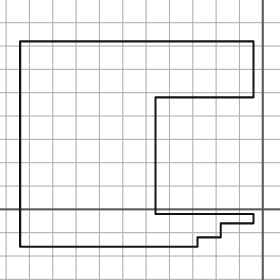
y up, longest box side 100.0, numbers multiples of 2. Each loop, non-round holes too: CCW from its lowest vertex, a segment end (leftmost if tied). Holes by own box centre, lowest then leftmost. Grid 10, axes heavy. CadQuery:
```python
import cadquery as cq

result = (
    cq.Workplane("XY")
    .moveTo(-104.0, -16.0)
    .lineTo(-28.0, -16.0)
    .lineTo(-28.0, -12.0)
    .lineTo(-18.0, -12.0)
    .lineTo(-18.0, -6.0)
    .lineTo(-4.0, -6.0)
    .lineTo(-4.0, -2.0)
    .lineTo(-46.0, -2.0)
    .lineTo(-46.0, 48.0)
    .lineTo(-4.0, 48.0)
    .lineTo(-4.0, 72.0)
    .lineTo(-104.0, 72.0)
    .close()
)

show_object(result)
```